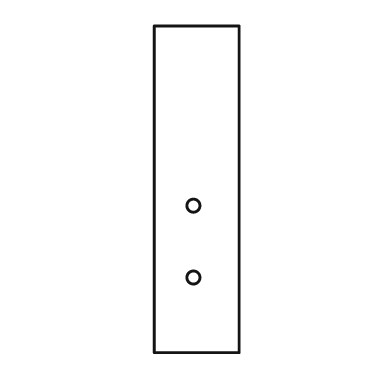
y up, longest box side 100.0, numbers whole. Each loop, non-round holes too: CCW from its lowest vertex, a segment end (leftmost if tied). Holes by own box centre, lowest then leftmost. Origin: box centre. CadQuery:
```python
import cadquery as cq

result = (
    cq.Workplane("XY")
    .moveTo(-13.0, -50.0)
    .lineTo(13.0, -50.0)
    .lineTo(13.0, 50.0)
    .lineTo(-13.0, 50.0)
    .close()
    .moveTo(-1.0, -27.0)
    .circle(2.0)
    .moveTo(-1.0, -5.0)
    .circle(2.0)
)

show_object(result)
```